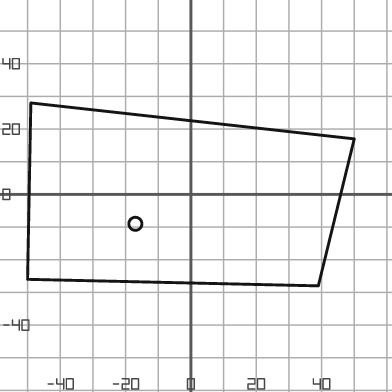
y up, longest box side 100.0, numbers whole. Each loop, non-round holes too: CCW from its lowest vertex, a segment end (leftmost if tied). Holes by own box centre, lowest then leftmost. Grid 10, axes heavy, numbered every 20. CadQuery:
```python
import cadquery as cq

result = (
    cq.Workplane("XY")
    .moveTo(39.0, -28.0)
    .lineTo(50.0, 17.0)
    .lineTo(-49.0, 28.0)
    .lineTo(-50.0, -26.0)
    .close()
    .moveTo(-17.0, -9.0)
    .circle(2.0)
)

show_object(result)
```